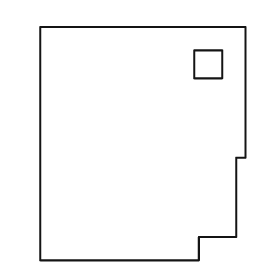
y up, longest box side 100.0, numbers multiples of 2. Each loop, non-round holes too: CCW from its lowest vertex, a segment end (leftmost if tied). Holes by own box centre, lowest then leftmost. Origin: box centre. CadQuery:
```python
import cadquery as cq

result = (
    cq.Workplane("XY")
    .moveTo(-44.0, -50.0)
    .lineTo(24.0, -50.0)
    .lineTo(24.0, -40.0)
    .lineTo(40.0, -40.0)
    .lineTo(40.0, -6.0)
    .lineTo(44.0, -6.0)
    .lineTo(44.0, 50.0)
    .lineTo(-44.0, 50.0)
    .close()
    .moveTo(22.0, 28.0)
    .lineTo(34.0, 28.0)
    .lineTo(34.0, 40.0)
    .lineTo(22.0, 40.0)
    .close()
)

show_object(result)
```